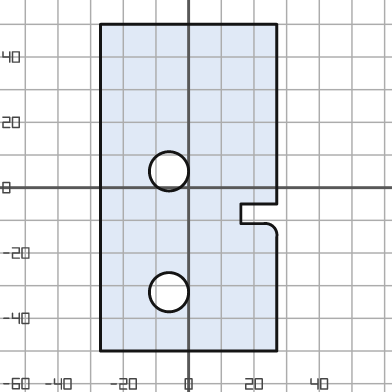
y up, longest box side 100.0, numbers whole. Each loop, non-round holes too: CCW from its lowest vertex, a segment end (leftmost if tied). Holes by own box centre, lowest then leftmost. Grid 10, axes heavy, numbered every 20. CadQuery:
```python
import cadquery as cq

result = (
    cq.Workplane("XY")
    .moveTo(-27.0, -50.0)
    .lineTo(27.0, -50.0)
    .lineTo(27.0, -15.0)
    .threePointArc((26.0, -12.0), (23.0, -11.0))
    .lineTo(16.0, -11.0)
    .lineTo(16.0, -5.0)
    .lineTo(27.0, -5.0)
    .lineTo(27.0, 50.0)
    .lineTo(-27.0, 50.0)
    .close()
    .moveTo(-6.0, -32.0)
    .circle(6.0)
    .moveTo(-6.0, 5.0)
    .circle(6.0)
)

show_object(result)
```